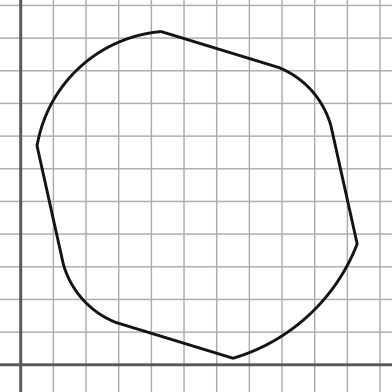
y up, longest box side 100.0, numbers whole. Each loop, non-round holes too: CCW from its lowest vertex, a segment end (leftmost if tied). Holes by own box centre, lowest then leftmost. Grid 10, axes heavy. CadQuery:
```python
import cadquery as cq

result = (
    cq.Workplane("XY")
    .moveTo(65.0, 2.0)
    .threePointArc((88.0, 15.0), (103.0, 37.0))
    .lineTo(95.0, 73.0)
    .threePointArc((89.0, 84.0), (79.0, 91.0))
    .lineTo(43.0, 102.0)
    .threePointArc((18.0, 91.0), (5.0, 67.0))
    .lineTo(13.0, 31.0)
    .threePointArc((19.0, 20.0), (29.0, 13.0))
    .close()
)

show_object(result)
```